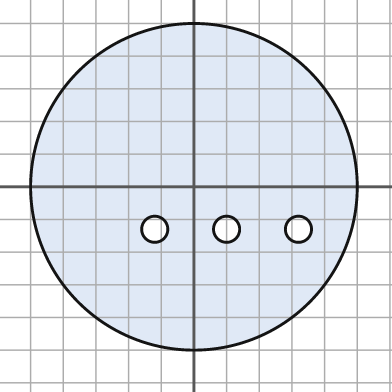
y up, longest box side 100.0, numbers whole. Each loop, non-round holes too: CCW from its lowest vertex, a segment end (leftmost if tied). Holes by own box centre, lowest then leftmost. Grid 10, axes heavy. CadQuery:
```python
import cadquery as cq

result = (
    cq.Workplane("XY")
    .moveTo(0.0, 0.0)
    .circle(50.0)
    .moveTo(-12.0, -13.0)
    .circle(4.0)
    .moveTo(10.0, -13.0)
    .circle(4.0)
    .moveTo(32.0, -13.0)
    .circle(4.0)
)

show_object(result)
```